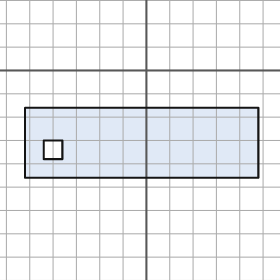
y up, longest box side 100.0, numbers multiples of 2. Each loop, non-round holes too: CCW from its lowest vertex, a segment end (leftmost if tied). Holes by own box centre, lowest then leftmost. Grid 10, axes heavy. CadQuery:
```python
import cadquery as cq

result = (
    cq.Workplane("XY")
    .moveTo(-52.0, -46.0)
    .lineTo(48.0, -46.0)
    .lineTo(48.0, -16.0)
    .lineTo(-52.0, -16.0)
    .close()
    .moveTo(-44.0, -38.0)
    .lineTo(-36.0, -38.0)
    .lineTo(-36.0, -30.0)
    .lineTo(-44.0, -30.0)
    .close()
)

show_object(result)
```